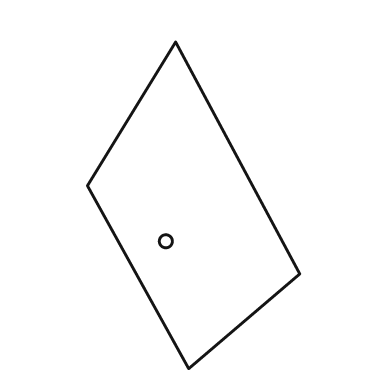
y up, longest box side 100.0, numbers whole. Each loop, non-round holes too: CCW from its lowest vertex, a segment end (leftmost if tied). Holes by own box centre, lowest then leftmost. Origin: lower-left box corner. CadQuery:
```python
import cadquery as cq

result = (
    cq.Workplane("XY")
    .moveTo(31.0, 0.0)
    .lineTo(65.0, 29.0)
    .lineTo(27.0, 100.0)
    .lineTo(0.0, 56.0)
    .close()
    .moveTo(24.0, 39.0)
    .circle(2.0)
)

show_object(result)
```